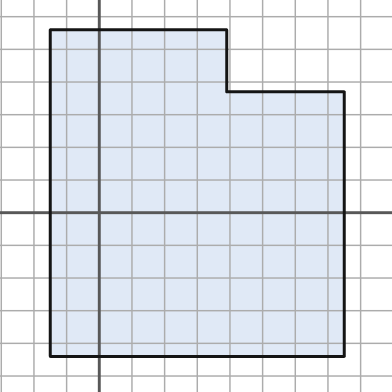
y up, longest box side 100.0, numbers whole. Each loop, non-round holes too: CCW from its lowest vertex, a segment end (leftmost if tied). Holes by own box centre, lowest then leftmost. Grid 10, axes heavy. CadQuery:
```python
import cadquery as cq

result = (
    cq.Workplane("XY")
    .moveTo(-15.0, -44.0)
    .lineTo(75.0, -44.0)
    .lineTo(75.0, 37.0)
    .lineTo(39.0, 37.0)
    .lineTo(39.0, 56.0)
    .lineTo(-15.0, 56.0)
    .close()
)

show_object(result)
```